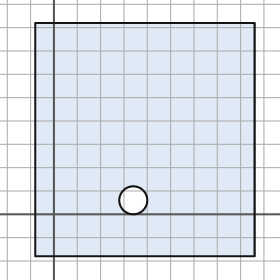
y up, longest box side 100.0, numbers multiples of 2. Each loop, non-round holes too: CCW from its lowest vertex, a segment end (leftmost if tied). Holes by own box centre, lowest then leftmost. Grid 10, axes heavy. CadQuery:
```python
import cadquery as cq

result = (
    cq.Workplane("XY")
    .moveTo(-8.0, -18.0)
    .lineTo(86.0, -18.0)
    .lineTo(86.0, 82.0)
    .lineTo(-8.0, 82.0)
    .close()
    .moveTo(34.0, 6.0)
    .circle(6.0)
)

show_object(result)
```